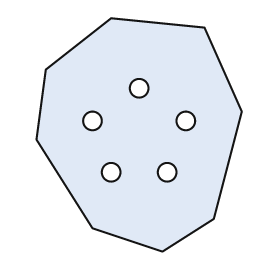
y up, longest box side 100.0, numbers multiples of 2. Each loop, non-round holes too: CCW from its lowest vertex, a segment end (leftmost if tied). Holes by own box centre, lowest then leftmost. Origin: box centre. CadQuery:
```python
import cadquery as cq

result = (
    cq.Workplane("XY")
    .moveTo(10.0, -50.0)
    .lineTo(32.0, -36.0)
    .lineTo(44.0, 10.0)
    .lineTo(28.0, 46.0)
    .lineTo(-12.0, 50.0)
    .lineTo(-40.0, 28.0)
    .lineTo(-44.0, -2.0)
    .lineTo(-20.0, -40.0)
    .close()
    .moveTo(-12.0, -16.0)
    .circle(4.0)
    .moveTo(12.0, -16.0)
    .circle(4.0)
    .moveTo(-20.0, 6.0)
    .circle(4.0)
    .moveTo(20.0, 6.0)
    .circle(4.0)
    .moveTo(0.0, 20.0)
    .circle(4.0)
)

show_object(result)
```